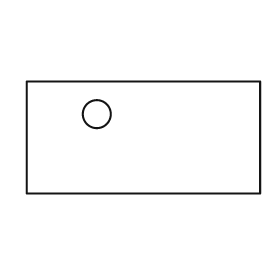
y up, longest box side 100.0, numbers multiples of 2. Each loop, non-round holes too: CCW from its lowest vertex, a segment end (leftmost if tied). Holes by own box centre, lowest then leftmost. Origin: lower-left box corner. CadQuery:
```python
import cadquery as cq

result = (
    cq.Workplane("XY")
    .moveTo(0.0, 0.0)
    .lineTo(100.0, 0.0)
    .lineTo(100.0, 48.0)
    .lineTo(0.0, 48.0)
    .close()
    .moveTo(30.0, 34.0)
    .circle(6.0)
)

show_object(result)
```